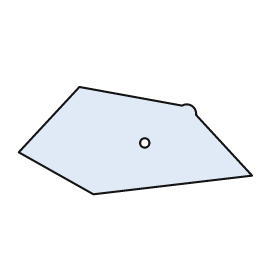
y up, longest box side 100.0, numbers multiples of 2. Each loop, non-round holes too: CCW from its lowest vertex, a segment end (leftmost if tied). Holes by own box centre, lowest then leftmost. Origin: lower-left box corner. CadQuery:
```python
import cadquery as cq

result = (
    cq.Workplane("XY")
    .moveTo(32.0, 0.0)
    .lineTo(100.0, 8.0)
    .lineTo(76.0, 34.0)
    .threePointArc((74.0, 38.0), (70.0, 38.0))
    .lineTo(26.0, 46.0)
    .lineTo(0.0, 18.0)
    .close()
    .moveTo(54.0, 22.0)
    .circle(2.0)
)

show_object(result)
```